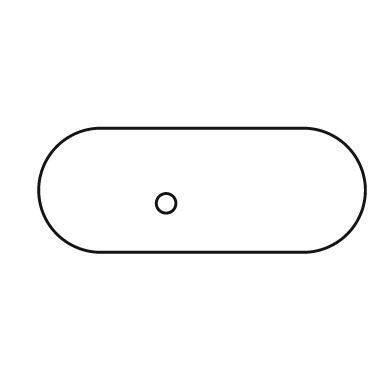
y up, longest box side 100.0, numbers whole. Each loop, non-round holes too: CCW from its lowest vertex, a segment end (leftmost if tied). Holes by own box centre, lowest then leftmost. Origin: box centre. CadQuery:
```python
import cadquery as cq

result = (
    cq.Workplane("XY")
    .moveTo(-31.0, -19.0)
    .lineTo(31.0, -19.0)
    .threePointArc((50.0, 0.0), (31.0, 19.0))
    .lineTo(-31.0, 19.0)
    .threePointArc((-50.0, 0.0), (-31.0, -19.0))
    .close()
    .moveTo(-11.0, -4.0)
    .circle(3.0)
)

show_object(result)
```